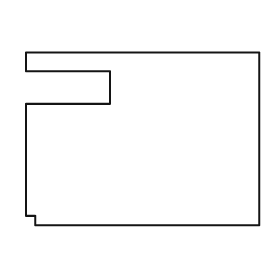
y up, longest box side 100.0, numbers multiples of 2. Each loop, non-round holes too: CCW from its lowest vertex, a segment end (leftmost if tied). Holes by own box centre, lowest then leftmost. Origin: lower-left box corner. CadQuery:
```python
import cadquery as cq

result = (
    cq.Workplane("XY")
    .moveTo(4.0, 0.0)
    .lineTo(100.0, 0.0)
    .lineTo(100.0, 74.0)
    .lineTo(0.0, 74.0)
    .lineTo(0.0, 66.0)
    .lineTo(36.0, 66.0)
    .lineTo(36.0, 52.0)
    .lineTo(0.0, 52.0)
    .lineTo(0.0, 4.0)
    .lineTo(4.0, 4.0)
    .close()
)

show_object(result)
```